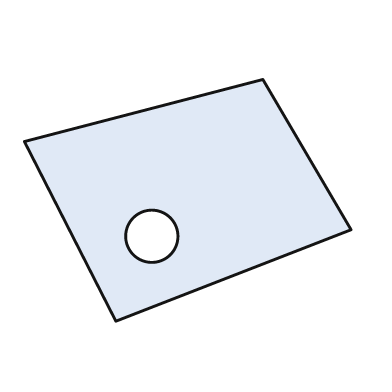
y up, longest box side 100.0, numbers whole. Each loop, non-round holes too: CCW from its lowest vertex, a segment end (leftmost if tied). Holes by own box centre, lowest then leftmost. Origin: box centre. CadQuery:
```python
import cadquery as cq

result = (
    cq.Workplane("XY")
    .moveTo(-22.0, -37.0)
    .lineTo(50.0, -9.0)
    .lineTo(23.0, 37.0)
    .lineTo(-50.0, 18.0)
    .close()
    .moveTo(-11.0, -11.0)
    .circle(8.0)
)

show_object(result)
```